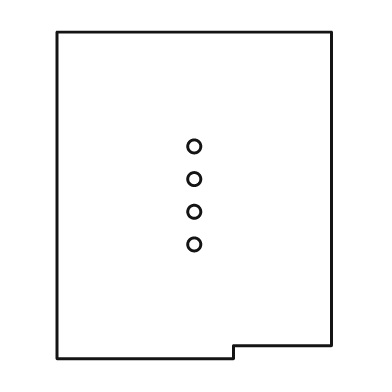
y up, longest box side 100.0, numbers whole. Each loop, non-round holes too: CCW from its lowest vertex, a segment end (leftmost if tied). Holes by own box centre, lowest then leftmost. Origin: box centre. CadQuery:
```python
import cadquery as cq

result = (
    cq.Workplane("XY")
    .moveTo(-42.0, -50.0)
    .lineTo(12.0, -50.0)
    .lineTo(12.0, -46.0)
    .lineTo(42.0, -46.0)
    .lineTo(42.0, 50.0)
    .lineTo(-42.0, 50.0)
    .close()
    .moveTo(0.0, -15.0)
    .circle(2.0)
    .moveTo(0.0, -5.0)
    .circle(2.0)
    .moveTo(0.0, 5.0)
    .circle(2.0)
    .moveTo(0.0, 15.0)
    .circle(2.0)
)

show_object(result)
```